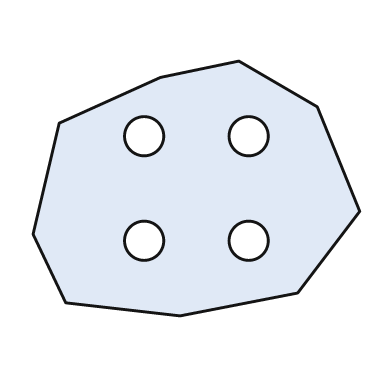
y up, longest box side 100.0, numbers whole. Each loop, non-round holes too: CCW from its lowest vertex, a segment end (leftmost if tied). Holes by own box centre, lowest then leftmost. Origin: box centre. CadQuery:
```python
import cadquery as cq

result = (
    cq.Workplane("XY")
    .moveTo(-5.0, -39.0)
    .lineTo(31.0, -32.0)
    .lineTo(50.0, -7.0)
    .lineTo(37.0, 25.0)
    .lineTo(13.0, 39.0)
    .lineTo(-11.0, 34.0)
    .lineTo(-42.0, 20.0)
    .lineTo(-50.0, -14.0)
    .lineTo(-40.0, -35.0)
    .close()
    .moveTo(-16.0, -16.0)
    .circle(6.0)
    .moveTo(16.0, -16.0)
    .circle(6.0)
    .moveTo(-16.0, 16.0)
    .circle(6.0)
    .moveTo(16.0, 16.0)
    .circle(6.0)
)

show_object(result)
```